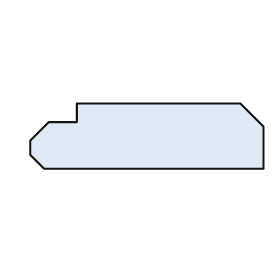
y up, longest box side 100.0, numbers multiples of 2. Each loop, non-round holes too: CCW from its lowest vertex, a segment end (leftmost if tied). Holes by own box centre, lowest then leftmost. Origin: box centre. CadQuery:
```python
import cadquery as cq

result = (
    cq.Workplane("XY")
    .moveTo(-44.0, -14.0)
    .lineTo(50.0, -14.0)
    .lineTo(50.0, 4.0)
    .lineTo(40.0, 14.0)
    .lineTo(-30.0, 14.0)
    .lineTo(-30.0, 6.0)
    .lineTo(-42.0, 6.0)
    .lineTo(-50.0, -2.0)
    .lineTo(-50.0, -8.0)
    .close()
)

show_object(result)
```